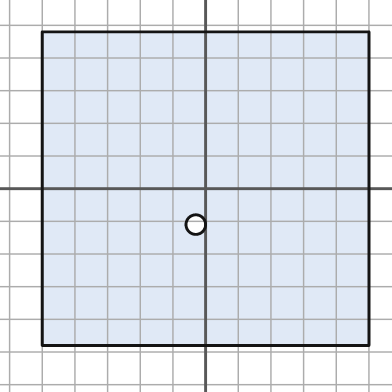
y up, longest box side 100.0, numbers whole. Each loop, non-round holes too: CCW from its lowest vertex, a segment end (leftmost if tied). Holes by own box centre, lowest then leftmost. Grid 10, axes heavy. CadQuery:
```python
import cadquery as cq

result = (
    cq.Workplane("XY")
    .moveTo(-50.0, -48.0)
    .lineTo(50.0, -48.0)
    .lineTo(50.0, 48.0)
    .lineTo(-50.0, 48.0)
    .close()
    .moveTo(-3.0, -11.0)
    .circle(3.0)
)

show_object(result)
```